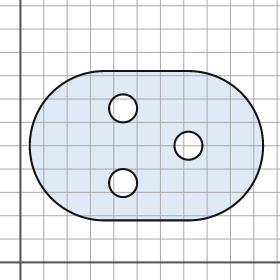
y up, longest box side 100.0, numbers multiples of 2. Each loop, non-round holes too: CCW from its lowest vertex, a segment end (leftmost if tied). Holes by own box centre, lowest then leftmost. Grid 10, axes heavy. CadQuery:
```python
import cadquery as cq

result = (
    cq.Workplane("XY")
    .moveTo(36.0, 18.0)
    .lineTo(72.0, 18.0)
    .threePointArc((104.0, 50.0), (72.0, 82.0))
    .lineTo(36.0, 82.0)
    .threePointArc((4.0, 50.0), (36.0, 18.0))
    .close()
    .moveTo(44.0, 34.0)
    .circle(6.0)
    .moveTo(72.0, 50.0)
    .circle(6.0)
    .moveTo(44.0, 66.0)
    .circle(6.0)
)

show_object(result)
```